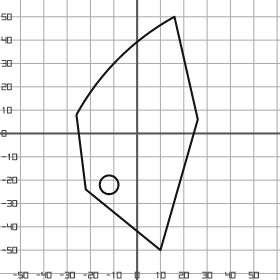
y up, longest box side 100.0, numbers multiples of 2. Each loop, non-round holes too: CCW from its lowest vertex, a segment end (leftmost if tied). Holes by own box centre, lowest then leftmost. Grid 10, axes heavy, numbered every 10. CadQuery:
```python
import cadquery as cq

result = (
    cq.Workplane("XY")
    .moveTo(10.0, -50.0)
    .lineTo(26.0, 6.0)
    .lineTo(16.0, 50.0)
    .threePointArc((-8.0, 32.0), (-26.0, 8.0))
    .lineTo(-22.0, -24.0)
    .close()
    .moveTo(-12.0, -22.0)
    .circle(4.0)
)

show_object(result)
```